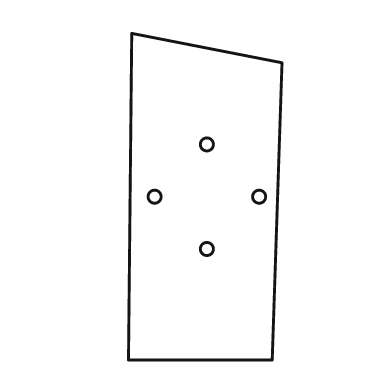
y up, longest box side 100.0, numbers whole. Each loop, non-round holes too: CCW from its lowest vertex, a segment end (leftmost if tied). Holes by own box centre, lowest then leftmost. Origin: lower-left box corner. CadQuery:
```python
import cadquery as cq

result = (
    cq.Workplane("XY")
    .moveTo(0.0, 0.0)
    .lineTo(44.0, 0.0)
    .lineTo(47.0, 91.0)
    .lineTo(1.0, 100.0)
    .close()
    .moveTo(24.0, 34.0)
    .circle(2.0)
    .moveTo(8.0, 50.0)
    .circle(2.0)
    .moveTo(40.0, 50.0)
    .circle(2.0)
    .moveTo(24.0, 66.0)
    .circle(2.0)
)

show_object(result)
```